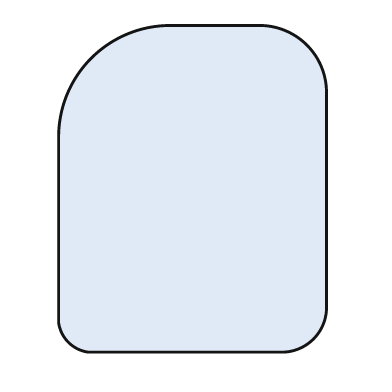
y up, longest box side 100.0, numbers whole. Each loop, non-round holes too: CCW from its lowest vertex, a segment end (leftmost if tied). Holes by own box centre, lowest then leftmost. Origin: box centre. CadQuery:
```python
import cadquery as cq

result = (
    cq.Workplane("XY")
    .moveTo(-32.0, -50.0)
    .lineTo(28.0, -50.0)
    .threePointArc((37.0, -46.0), (41.0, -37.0))
    .lineTo(41.0, 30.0)
    .threePointArc((35.0, 44.0), (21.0, 50.0))
    .lineTo(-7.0, 50.0)
    .threePointArc((-31.0, 40.0), (-41.0, 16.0))
    .lineTo(-41.0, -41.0)
    .threePointArc((-38.0, -47.0), (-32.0, -50.0))
    .close()
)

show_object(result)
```